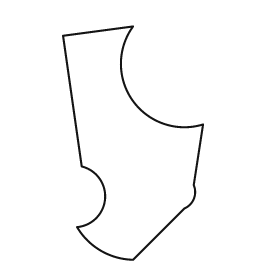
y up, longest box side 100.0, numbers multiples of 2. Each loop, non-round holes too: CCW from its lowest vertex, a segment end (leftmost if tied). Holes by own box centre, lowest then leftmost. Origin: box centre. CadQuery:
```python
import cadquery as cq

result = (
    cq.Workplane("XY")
    .moveTo(0.0, -50.0)
    .lineTo(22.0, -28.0)
    .threePointArc((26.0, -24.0), (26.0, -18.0))
    .lineTo(30.0, 8.0)
    .threePointArc((0.0, 18.0), (0.0, 50.0))
    .lineTo(-30.0, 46.0)
    .lineTo(-22.0, -10.0)
    .threePointArc((-12.0, -24.0), (-24.0, -36.0))
    .threePointArc((-14.0, -46.0), (0.0, -50.0))
    .close()
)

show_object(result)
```